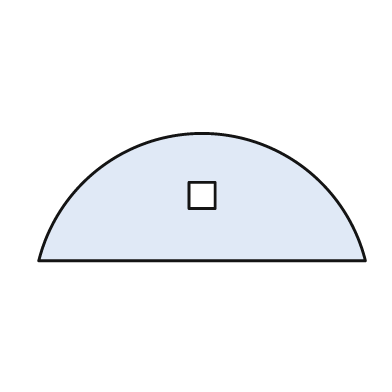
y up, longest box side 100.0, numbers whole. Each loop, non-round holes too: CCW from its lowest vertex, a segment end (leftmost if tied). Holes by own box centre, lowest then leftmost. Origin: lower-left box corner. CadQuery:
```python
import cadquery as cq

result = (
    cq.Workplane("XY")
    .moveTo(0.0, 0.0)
    .lineTo(100.0, 0.0)
    .threePointArc((50.0, 39.0), (0.0, 0.0))
    .close()
    .moveTo(46.0, 16.0)
    .lineTo(54.0, 16.0)
    .lineTo(54.0, 24.0)
    .lineTo(46.0, 24.0)
    .close()
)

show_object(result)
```